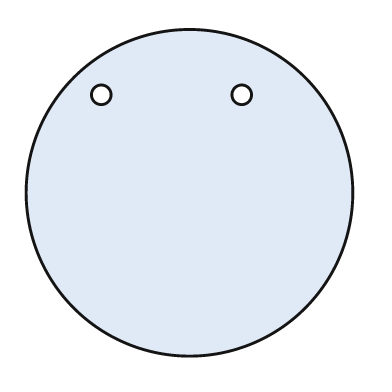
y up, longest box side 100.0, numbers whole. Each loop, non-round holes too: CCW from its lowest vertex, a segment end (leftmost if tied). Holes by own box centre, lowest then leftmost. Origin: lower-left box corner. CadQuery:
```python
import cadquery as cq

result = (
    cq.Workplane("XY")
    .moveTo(50.0, 50.0)
    .circle(50.0)
    .moveTo(23.0, 80.0)
    .circle(3.0)
    .moveTo(66.0, 80.0)
    .circle(3.0)
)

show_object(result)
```